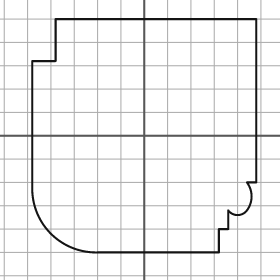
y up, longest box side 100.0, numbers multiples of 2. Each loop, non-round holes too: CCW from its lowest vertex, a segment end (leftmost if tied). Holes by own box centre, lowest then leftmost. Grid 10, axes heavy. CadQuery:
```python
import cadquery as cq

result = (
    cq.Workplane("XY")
    .moveTo(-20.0, -50.0)
    .lineTo(32.0, -50.0)
    .lineTo(32.0, -40.0)
    .lineTo(36.0, -40.0)
    .lineTo(36.0, -32.0)
    .threePointArc((40.0, -34.0), (44.0, -32.0))
    .threePointArc((46.0, -26.0), (44.0, -20.0))
    .lineTo(48.0, -20.0)
    .lineTo(48.0, 50.0)
    .lineTo(-38.0, 50.0)
    .lineTo(-38.0, 32.0)
    .lineTo(-48.0, 32.0)
    .lineTo(-48.0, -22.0)
    .threePointArc((-40.0, -42.0), (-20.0, -50.0))
    .close()
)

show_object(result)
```